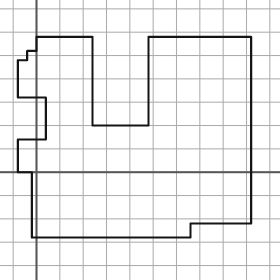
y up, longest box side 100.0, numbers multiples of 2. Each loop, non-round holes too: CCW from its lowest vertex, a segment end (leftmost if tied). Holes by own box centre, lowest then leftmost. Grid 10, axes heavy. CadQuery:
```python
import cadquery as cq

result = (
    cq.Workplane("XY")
    .moveTo(-2.0, -28.0)
    .lineTo(66.0, -28.0)
    .lineTo(66.0, -22.0)
    .lineTo(92.0, -22.0)
    .lineTo(92.0, 58.0)
    .lineTo(48.0, 58.0)
    .lineTo(48.0, 20.0)
    .lineTo(24.0, 20.0)
    .lineTo(24.0, 58.0)
    .lineTo(0.0, 58.0)
    .lineTo(0.0, 52.0)
    .lineTo(-4.0, 52.0)
    .lineTo(-4.0, 48.0)
    .lineTo(-8.0, 48.0)
    .lineTo(-8.0, 32.0)
    .lineTo(4.0, 32.0)
    .lineTo(4.0, 14.0)
    .lineTo(-8.0, 14.0)
    .lineTo(-8.0, 0.0)
    .lineTo(-2.0, 0.0)
    .close()
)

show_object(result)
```